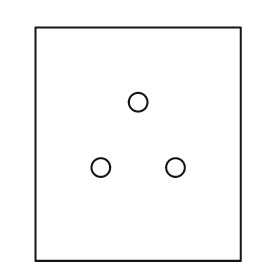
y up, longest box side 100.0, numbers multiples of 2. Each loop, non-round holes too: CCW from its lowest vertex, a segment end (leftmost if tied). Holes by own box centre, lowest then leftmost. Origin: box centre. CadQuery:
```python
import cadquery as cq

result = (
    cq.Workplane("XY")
    .moveTo(-44.0, -50.0)
    .lineTo(44.0, -50.0)
    .lineTo(44.0, 50.0)
    .lineTo(-44.0, 50.0)
    .close()
    .moveTo(-16.0, -10.0)
    .circle(4.0)
    .moveTo(16.0, -10.0)
    .circle(4.0)
    .moveTo(0.0, 18.0)
    .circle(4.0)
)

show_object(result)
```